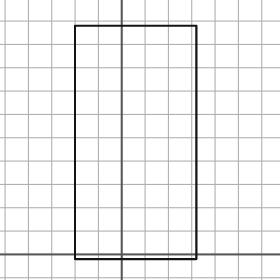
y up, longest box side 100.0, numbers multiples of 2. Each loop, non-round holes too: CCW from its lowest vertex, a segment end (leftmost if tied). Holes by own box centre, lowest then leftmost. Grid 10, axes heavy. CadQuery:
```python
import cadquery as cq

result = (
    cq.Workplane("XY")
    .moveTo(-20.0, -2.0)
    .lineTo(32.0, -2.0)
    .lineTo(32.0, 98.0)
    .lineTo(-20.0, 98.0)
    .close()
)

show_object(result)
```